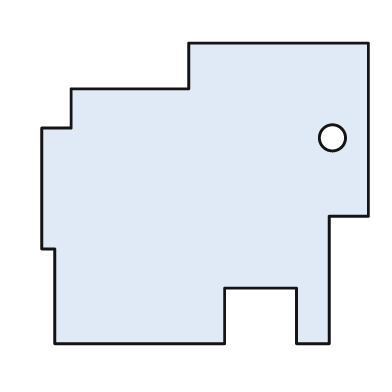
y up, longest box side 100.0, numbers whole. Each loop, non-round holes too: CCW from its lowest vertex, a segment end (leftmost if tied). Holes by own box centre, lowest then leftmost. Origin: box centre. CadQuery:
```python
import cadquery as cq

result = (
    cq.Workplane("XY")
    .moveTo(-46.0, -46.0)
    .lineTo(6.0, -46.0)
    .lineTo(6.0, -29.0)
    .lineTo(28.0, -29.0)
    .lineTo(28.0, -46.0)
    .lineTo(38.0, -46.0)
    .lineTo(38.0, -7.0)
    .lineTo(50.0, -7.0)
    .lineTo(50.0, 46.0)
    .lineTo(-5.0, 46.0)
    .lineTo(-5.0, 32.0)
    .lineTo(-41.0, 32.0)
    .lineTo(-41.0, 20.0)
    .lineTo(-50.0, 20.0)
    .lineTo(-50.0, -17.0)
    .lineTo(-46.0, -17.0)
    .close()
    .moveTo(39.0, 17.0)
    .circle(4.0)
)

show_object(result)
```